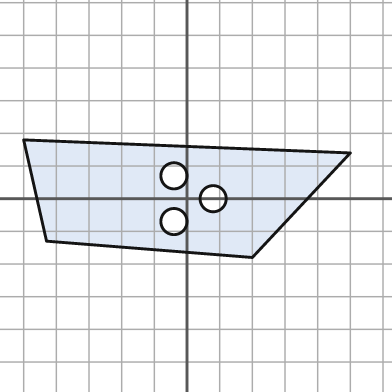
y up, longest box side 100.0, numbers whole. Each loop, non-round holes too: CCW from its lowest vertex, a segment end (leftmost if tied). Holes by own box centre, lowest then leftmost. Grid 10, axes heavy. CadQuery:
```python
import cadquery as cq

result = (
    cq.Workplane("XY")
    .moveTo(20.0, -18.0)
    .lineTo(50.0, 14.0)
    .lineTo(-50.0, 18.0)
    .lineTo(-43.0, -13.0)
    .close()
    .moveTo(-4.0, -7.0)
    .circle(4.0)
    .moveTo(8.0, 0.0)
    .circle(4.0)
    .moveTo(-4.0, 7.0)
    .circle(4.0)
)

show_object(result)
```